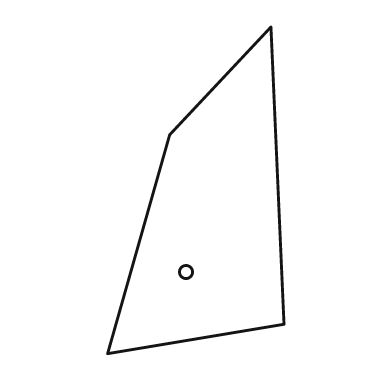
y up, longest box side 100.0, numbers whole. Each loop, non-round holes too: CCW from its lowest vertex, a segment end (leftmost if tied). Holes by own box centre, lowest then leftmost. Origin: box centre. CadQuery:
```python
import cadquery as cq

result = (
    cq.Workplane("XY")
    .moveTo(-27.0, -50.0)
    .lineTo(27.0, -41.0)
    .lineTo(23.0, 50.0)
    .lineTo(-8.0, 17.0)
    .close()
    .moveTo(-3.0, -25.0)
    .circle(2.0)
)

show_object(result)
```